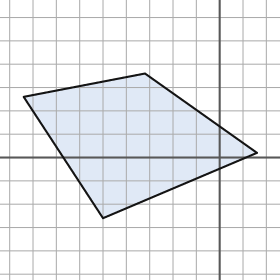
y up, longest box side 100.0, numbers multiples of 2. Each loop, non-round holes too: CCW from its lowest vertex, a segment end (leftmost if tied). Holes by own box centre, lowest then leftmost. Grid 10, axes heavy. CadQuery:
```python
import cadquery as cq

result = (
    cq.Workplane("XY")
    .moveTo(-50.0, -26.0)
    .lineTo(16.0, 2.0)
    .lineTo(-32.0, 36.0)
    .lineTo(-84.0, 26.0)
    .close()
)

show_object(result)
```